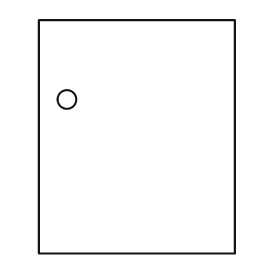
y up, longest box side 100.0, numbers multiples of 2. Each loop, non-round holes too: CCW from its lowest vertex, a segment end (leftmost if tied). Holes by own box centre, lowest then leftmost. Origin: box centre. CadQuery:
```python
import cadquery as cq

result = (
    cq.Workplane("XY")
    .moveTo(-42.0, -50.0)
    .lineTo(42.0, -50.0)
    .lineTo(42.0, 50.0)
    .lineTo(-42.0, 50.0)
    .close()
    .moveTo(-30.0, 16.0)
    .circle(4.0)
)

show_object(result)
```